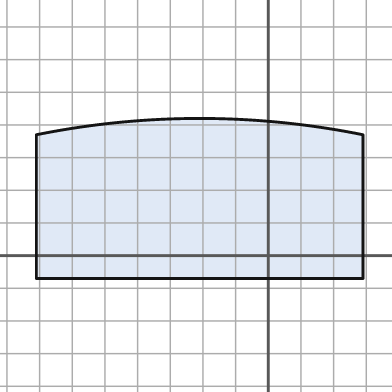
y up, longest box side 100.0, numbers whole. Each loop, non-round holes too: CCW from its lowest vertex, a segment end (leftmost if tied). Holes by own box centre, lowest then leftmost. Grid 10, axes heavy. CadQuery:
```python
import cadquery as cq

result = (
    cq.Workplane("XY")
    .moveTo(-71.0, -7.0)
    .lineTo(29.0, -7.0)
    .lineTo(29.0, 37.0)
    .threePointArc((-21.0, 42.0), (-71.0, 37.0))
    .close()
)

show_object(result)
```